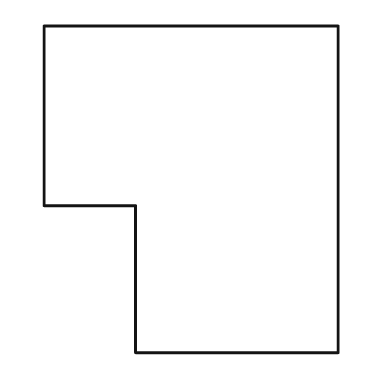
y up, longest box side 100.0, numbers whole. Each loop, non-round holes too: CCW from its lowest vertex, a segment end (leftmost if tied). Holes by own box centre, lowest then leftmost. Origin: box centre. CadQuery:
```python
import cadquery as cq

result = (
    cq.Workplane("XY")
    .moveTo(-17.0, -50.0)
    .lineTo(45.0, -50.0)
    .lineTo(45.0, 50.0)
    .lineTo(-45.0, 50.0)
    .lineTo(-45.0, -5.0)
    .lineTo(-17.0, -5.0)
    .close()
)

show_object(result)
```